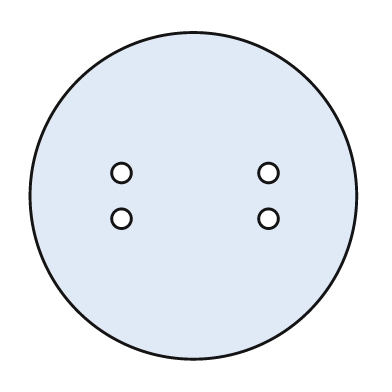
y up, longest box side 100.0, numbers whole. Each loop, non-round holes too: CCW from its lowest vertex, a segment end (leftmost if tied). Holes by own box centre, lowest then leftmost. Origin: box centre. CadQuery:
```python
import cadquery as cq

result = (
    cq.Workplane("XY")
    .moveTo(0.0, 0.0)
    .circle(50.0)
    .moveTo(-22.0, -7.0)
    .circle(3.0)
    .moveTo(23.0, -7.0)
    .circle(3.0)
    .moveTo(-22.0, 7.0)
    .circle(3.0)
    .moveTo(23.0, 7.0)
    .circle(3.0)
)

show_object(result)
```